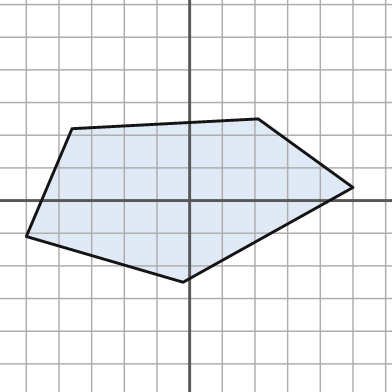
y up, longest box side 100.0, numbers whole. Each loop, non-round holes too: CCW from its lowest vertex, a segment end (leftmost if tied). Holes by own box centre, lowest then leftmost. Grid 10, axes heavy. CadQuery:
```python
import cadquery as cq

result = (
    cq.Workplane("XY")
    .moveTo(-2.0, -25.0)
    .lineTo(50.0, 4.0)
    .lineTo(21.0, 25.0)
    .lineTo(-36.0, 22.0)
    .lineTo(-50.0, -11.0)
    .close()
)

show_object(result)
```